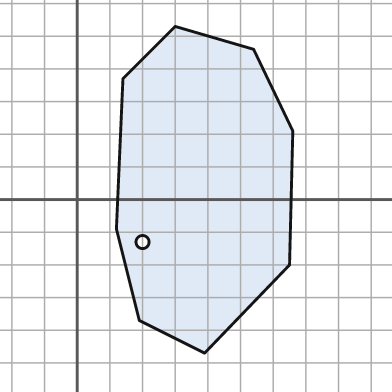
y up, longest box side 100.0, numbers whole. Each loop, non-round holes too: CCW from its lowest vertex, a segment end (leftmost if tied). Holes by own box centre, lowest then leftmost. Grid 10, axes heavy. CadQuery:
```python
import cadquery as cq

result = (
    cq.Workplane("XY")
    .moveTo(39.0, -47.0)
    .lineTo(65.0, -20.0)
    .lineTo(66.0, 21.0)
    .lineTo(54.0, 46.0)
    .lineTo(30.0, 53.0)
    .lineTo(14.0, 37.0)
    .lineTo(12.0, -9.0)
    .lineTo(19.0, -37.0)
    .close()
    .moveTo(20.0, -13.0)
    .circle(2.0)
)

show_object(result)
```